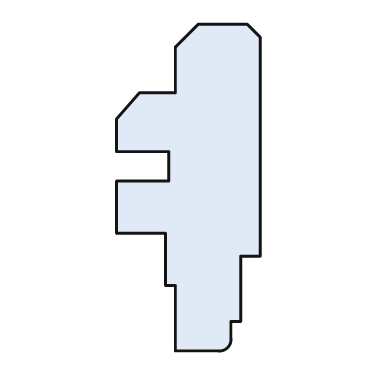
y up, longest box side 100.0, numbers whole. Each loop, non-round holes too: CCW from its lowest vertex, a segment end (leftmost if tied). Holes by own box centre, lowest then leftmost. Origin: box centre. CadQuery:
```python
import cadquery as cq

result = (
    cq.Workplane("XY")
    .moveTo(-4.0, -50.0)
    .lineTo(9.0, -50.0)
    .threePointArc((12.0, -49.0), (13.0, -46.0))
    .lineTo(13.0, -41.0)
    .lineTo(16.0, -41.0)
    .lineTo(16.0, -21.0)
    .lineTo(22.0, -21.0)
    .lineTo(22.0, 46.0)
    .lineTo(18.0, 50.0)
    .lineTo(3.0, 50.0)
    .lineTo(-4.0, 43.0)
    .lineTo(-4.0, 29.0)
    .lineTo(-15.0, 29.0)
    .lineTo(-22.0, 21.0)
    .lineTo(-22.0, 11.0)
    .lineTo(-6.0, 11.0)
    .lineTo(-6.0, 2.0)
    .lineTo(-22.0, 2.0)
    .lineTo(-22.0, -14.0)
    .lineTo(-7.0, -14.0)
    .lineTo(-7.0, -30.0)
    .lineTo(-4.0, -30.0)
    .close()
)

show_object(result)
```